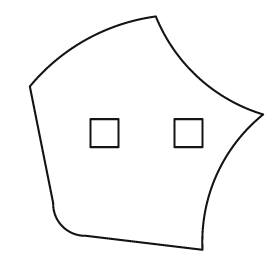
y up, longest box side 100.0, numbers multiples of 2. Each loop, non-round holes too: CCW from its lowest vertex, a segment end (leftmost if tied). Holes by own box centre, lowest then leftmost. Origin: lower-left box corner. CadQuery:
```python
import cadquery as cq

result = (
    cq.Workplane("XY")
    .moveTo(74.0, 0.0)
    .threePointArc((80.0, 32.0), (100.0, 58.0))
    .threePointArc((72.0, 74.0), (54.0, 100.0))
    .threePointArc((24.0, 90.0), (0.0, 70.0))
    .lineTo(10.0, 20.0)
    .threePointArc((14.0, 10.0), (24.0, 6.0))
    .close()
    .moveTo(26.0, 44.0)
    .lineTo(38.0, 44.0)
    .lineTo(38.0, 56.0)
    .lineTo(26.0, 56.0)
    .close()
    .moveTo(62.0, 44.0)
    .lineTo(74.0, 44.0)
    .lineTo(74.0, 56.0)
    .lineTo(62.0, 56.0)
    .close()
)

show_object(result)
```